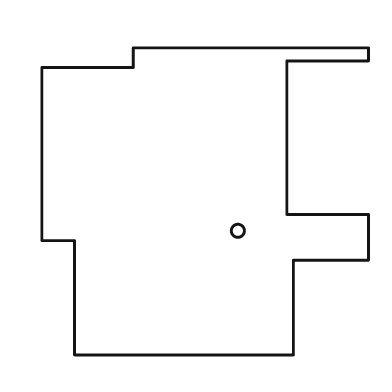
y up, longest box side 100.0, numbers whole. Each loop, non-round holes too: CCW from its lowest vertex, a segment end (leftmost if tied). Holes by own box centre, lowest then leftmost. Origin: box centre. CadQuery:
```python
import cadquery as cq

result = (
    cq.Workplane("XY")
    .moveTo(-40.0, -47.0)
    .lineTo(27.0, -47.0)
    .lineTo(27.0, -18.0)
    .lineTo(50.0, -18.0)
    .lineTo(50.0, -4.0)
    .lineTo(25.0, -4.0)
    .lineTo(25.0, 43.0)
    .lineTo(50.0, 43.0)
    .lineTo(50.0, 47.0)
    .lineTo(-22.0, 47.0)
    .lineTo(-22.0, 41.0)
    .lineTo(-50.0, 41.0)
    .lineTo(-50.0, -12.0)
    .lineTo(-40.0, -12.0)
    .close()
    .moveTo(10.0, -9.0)
    .circle(2.0)
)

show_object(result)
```